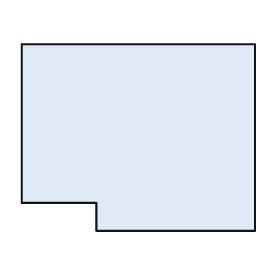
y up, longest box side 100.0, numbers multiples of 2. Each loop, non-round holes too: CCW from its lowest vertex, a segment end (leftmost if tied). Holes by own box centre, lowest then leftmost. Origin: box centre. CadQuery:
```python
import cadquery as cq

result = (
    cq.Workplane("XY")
    .moveTo(-18.0, -40.0)
    .lineTo(50.0, -40.0)
    .lineTo(50.0, 40.0)
    .lineTo(-50.0, 40.0)
    .lineTo(-50.0, -28.0)
    .lineTo(-18.0, -28.0)
    .close()
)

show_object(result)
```